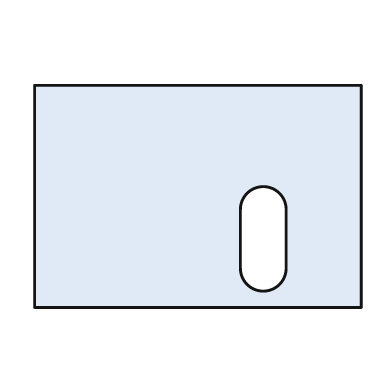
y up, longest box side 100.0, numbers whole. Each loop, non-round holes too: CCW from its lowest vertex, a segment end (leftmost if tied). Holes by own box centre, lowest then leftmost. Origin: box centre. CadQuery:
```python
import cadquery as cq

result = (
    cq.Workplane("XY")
    .moveTo(-50.0, -34.0)
    .lineTo(50.0, -34.0)
    .lineTo(50.0, 34.0)
    .lineTo(-50.0, 34.0)
    .close()
    .moveTo(13.0, -22.0)
    .threePointArc((20.0, -29.0), (27.0, -22.0))
    .lineTo(27.0, -4.0)
    .threePointArc((20.0, 3.0), (13.0, -4.0))
    .close()
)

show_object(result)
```